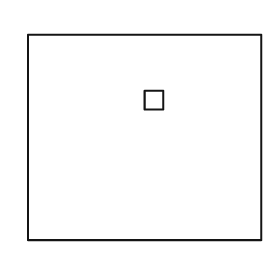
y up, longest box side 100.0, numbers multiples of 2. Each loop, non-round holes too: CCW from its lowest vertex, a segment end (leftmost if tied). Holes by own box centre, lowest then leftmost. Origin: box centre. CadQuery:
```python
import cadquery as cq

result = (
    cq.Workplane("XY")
    .moveTo(-50.0, -44.0)
    .lineTo(50.0, -44.0)
    .lineTo(50.0, 44.0)
    .lineTo(-50.0, 44.0)
    .close()
    .moveTo(0.0, 12.0)
    .lineTo(8.0, 12.0)
    .lineTo(8.0, 20.0)
    .lineTo(0.0, 20.0)
    .close()
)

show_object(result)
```